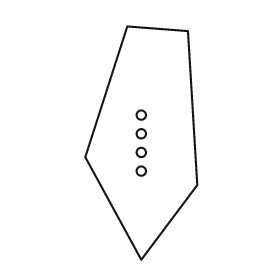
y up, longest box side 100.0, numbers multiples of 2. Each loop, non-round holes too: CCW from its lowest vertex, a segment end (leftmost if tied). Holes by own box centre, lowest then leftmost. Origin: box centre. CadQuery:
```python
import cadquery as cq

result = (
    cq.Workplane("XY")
    .moveTo(0.0, -50.0)
    .lineTo(24.0, -18.0)
    .lineTo(20.0, 48.0)
    .lineTo(-6.0, 50.0)
    .lineTo(-24.0, -6.0)
    .close()
    .moveTo(0.0, -12.0)
    .circle(2.0)
    .moveTo(0.0, -4.0)
    .circle(2.0)
    .moveTo(0.0, 4.0)
    .circle(2.0)
    .moveTo(0.0, 12.0)
    .circle(2.0)
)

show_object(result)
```